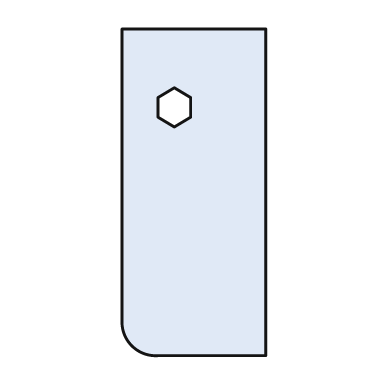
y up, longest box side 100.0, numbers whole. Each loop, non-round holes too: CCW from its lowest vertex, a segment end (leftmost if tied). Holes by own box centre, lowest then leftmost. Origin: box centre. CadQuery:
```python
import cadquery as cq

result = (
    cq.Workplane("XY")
    .moveTo(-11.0, -50.0)
    .lineTo(22.0, -50.0)
    .lineTo(22.0, 50.0)
    .lineTo(-22.0, 50.0)
    .lineTo(-22.0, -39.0)
    .threePointArc((-19.0, -47.0), (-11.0, -50.0))
    .close()
    .moveTo(-6.0, 20.0)
    .lineTo(-1.0, 23.0)
    .lineTo(-1.0, 29.0)
    .lineTo(-6.0, 32.0)
    .lineTo(-11.0, 29.0)
    .lineTo(-11.0, 23.0)
    .close()
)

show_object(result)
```